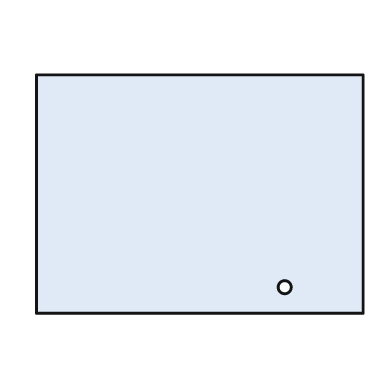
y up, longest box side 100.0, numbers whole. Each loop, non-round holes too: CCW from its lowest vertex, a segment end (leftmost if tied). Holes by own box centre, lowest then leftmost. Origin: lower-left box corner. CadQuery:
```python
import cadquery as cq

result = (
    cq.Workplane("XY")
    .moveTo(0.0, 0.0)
    .lineTo(100.0, 0.0)
    .lineTo(100.0, 73.0)
    .lineTo(0.0, 73.0)
    .close()
    .moveTo(76.0, 8.0)
    .circle(2.0)
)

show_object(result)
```